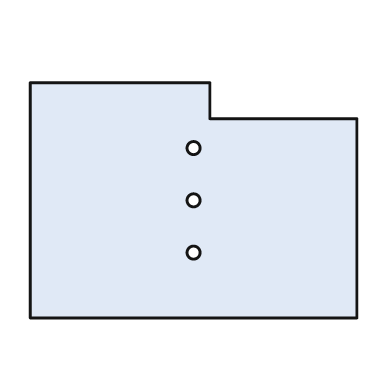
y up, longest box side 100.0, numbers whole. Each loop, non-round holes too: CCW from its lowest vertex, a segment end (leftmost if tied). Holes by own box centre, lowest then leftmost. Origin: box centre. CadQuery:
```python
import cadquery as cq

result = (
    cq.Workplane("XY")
    .moveTo(-50.0, -36.0)
    .lineTo(50.0, -36.0)
    .lineTo(50.0, 25.0)
    .lineTo(5.0, 25.0)
    .lineTo(5.0, 36.0)
    .lineTo(-50.0, 36.0)
    .close()
    .moveTo(0.0, -16.0)
    .circle(2.0)
    .moveTo(0.0, 0.0)
    .circle(2.0)
    .moveTo(0.0, 16.0)
    .circle(2.0)
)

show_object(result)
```